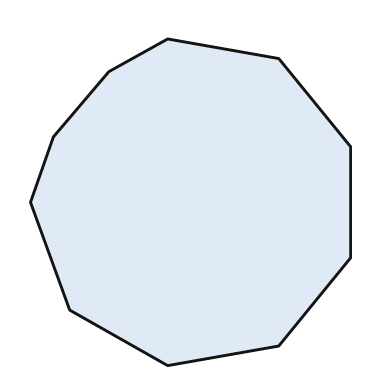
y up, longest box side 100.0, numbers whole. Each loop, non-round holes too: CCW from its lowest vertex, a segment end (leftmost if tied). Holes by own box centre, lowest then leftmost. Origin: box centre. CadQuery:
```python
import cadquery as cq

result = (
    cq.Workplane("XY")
    .moveTo(-7.0, -50.0)
    .lineTo(27.0, -44.0)
    .lineTo(49.0, -17.0)
    .lineTo(49.0, 17.0)
    .lineTo(27.0, 44.0)
    .lineTo(-7.0, 50.0)
    .lineTo(-25.0, 40.0)
    .lineTo(-42.0, 20.0)
    .lineTo(-49.0, 0.0)
    .lineTo(-37.0, -33.0)
    .close()
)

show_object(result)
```